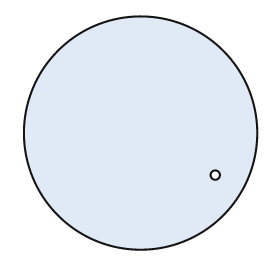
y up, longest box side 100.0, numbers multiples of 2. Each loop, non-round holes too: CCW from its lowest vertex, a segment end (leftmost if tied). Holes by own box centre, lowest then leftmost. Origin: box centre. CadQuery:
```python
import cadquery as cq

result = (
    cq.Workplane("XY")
    .moveTo(0.0, 0.0)
    .circle(50.0)
    .moveTo(32.0, -18.0)
    .circle(2.0)
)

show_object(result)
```